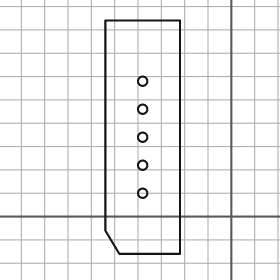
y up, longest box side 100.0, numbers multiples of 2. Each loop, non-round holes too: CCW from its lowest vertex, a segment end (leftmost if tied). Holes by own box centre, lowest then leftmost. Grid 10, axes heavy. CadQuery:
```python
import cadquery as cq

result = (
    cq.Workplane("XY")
    .moveTo(-48.0, -16.0)
    .lineTo(-22.0, -16.0)
    .lineTo(-22.0, 84.0)
    .lineTo(-54.0, 84.0)
    .lineTo(-54.0, -6.0)
    .close()
    .moveTo(-38.0, 10.0)
    .circle(2.0)
    .moveTo(-38.0, 22.0)
    .circle(2.0)
    .moveTo(-38.0, 34.0)
    .circle(2.0)
    .moveTo(-38.0, 46.0)
    .circle(2.0)
    .moveTo(-38.0, 58.0)
    .circle(2.0)
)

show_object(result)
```